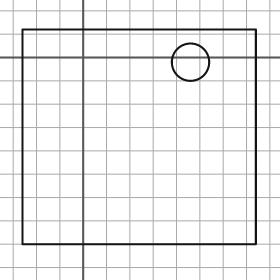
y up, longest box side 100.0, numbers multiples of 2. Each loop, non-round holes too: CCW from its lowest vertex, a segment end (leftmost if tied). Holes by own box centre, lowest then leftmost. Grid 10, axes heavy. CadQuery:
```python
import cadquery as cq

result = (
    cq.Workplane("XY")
    .moveTo(-26.0, -80.0)
    .lineTo(74.0, -80.0)
    .lineTo(74.0, 12.0)
    .lineTo(-26.0, 12.0)
    .close()
    .moveTo(46.0, -2.0)
    .circle(8.0)
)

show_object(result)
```